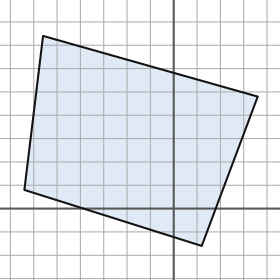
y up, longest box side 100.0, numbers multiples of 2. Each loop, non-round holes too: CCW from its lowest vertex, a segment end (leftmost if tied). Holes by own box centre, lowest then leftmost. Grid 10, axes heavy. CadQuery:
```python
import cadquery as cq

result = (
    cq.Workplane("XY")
    .moveTo(12.0, -16.0)
    .lineTo(36.0, 48.0)
    .lineTo(-56.0, 74.0)
    .lineTo(-64.0, 8.0)
    .close()
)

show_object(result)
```